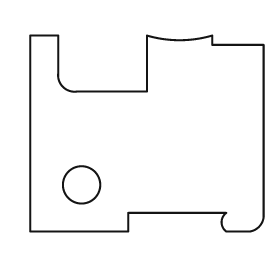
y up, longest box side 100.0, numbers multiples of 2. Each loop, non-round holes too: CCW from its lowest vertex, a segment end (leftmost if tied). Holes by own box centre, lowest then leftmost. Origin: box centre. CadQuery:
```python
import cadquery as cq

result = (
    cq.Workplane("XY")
    .moveTo(-50.0, -42.0)
    .lineTo(-8.0, -42.0)
    .lineTo(-8.0, -34.0)
    .lineTo(34.0, -34.0)
    .threePointArc((32.0, -38.0), (34.0, -42.0))
    .lineTo(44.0, -42.0)
    .threePointArc((48.0, -40.0), (50.0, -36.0))
    .lineTo(50.0, 38.0)
    .lineTo(28.0, 38.0)
    .lineTo(28.0, 42.0)
    .threePointArc((14.0, 40.0), (0.0, 42.0))
    .lineTo(0.0, 18.0)
    .lineTo(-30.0, 18.0)
    .threePointArc((-36.0, 20.0), (-38.0, 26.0))
    .lineTo(-38.0, 42.0)
    .lineTo(-50.0, 42.0)
    .close()
    .moveTo(-28.0, -22.0)
    .circle(8.0)
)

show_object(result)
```